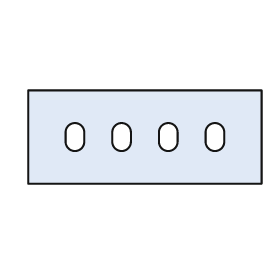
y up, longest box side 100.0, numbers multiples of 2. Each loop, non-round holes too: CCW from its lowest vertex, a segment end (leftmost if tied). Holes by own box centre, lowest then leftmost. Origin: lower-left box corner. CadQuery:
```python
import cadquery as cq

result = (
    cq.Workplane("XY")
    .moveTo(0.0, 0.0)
    .lineTo(100.0, 0.0)
    .lineTo(100.0, 40.0)
    .lineTo(0.0, 40.0)
    .close()
    .moveTo(16.0, 18.0)
    .threePointArc((20.0, 14.0), (24.0, 18.0))
    .lineTo(24.0, 22.0)
    .threePointArc((20.0, 26.0), (16.0, 22.0))
    .close()
    .moveTo(36.0, 18.0)
    .threePointArc((40.0, 14.0), (44.0, 18.0))
    .lineTo(44.0, 22.0)
    .threePointArc((40.0, 26.0), (36.0, 22.0))
    .close()
    .moveTo(56.0, 18.0)
    .threePointArc((60.0, 14.0), (64.0, 18.0))
    .lineTo(64.0, 22.0)
    .threePointArc((60.0, 26.0), (56.0, 22.0))
    .close()
    .moveTo(76.0, 18.0)
    .threePointArc((80.0, 14.0), (84.0, 18.0))
    .lineTo(84.0, 22.0)
    .threePointArc((80.0, 26.0), (76.0, 22.0))
    .close()
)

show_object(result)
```